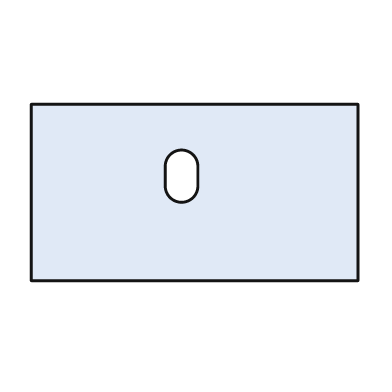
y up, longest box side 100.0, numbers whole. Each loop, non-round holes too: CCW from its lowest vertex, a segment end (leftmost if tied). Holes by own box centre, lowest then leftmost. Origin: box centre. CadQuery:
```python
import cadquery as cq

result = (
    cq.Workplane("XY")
    .moveTo(-50.0, -27.0)
    .lineTo(50.0, -27.0)
    .lineTo(50.0, 27.0)
    .lineTo(-50.0, 27.0)
    .close()
    .moveTo(-9.0, 2.0)
    .threePointArc((-4.0, -3.0), (1.0, 2.0))
    .lineTo(1.0, 8.0)
    .threePointArc((-4.0, 13.0), (-9.0, 8.0))
    .close()
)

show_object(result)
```